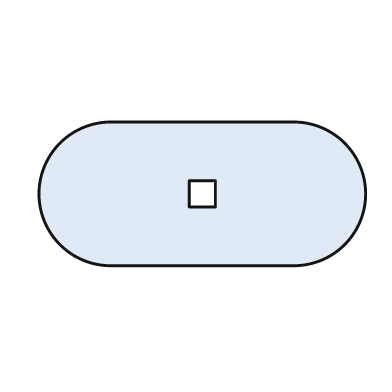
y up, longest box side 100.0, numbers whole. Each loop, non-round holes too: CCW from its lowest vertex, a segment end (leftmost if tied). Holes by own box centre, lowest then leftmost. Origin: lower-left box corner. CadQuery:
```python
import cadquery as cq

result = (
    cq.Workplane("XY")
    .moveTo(22.0, 0.0)
    .lineTo(78.0, 0.0)
    .threePointArc((100.0, 22.0), (78.0, 44.0))
    .lineTo(22.0, 44.0)
    .threePointArc((0.0, 22.0), (22.0, 0.0))
    .close()
    .moveTo(46.0, 18.0)
    .lineTo(54.0, 18.0)
    .lineTo(54.0, 26.0)
    .lineTo(46.0, 26.0)
    .close()
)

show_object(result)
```